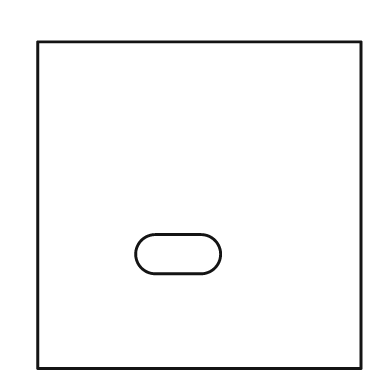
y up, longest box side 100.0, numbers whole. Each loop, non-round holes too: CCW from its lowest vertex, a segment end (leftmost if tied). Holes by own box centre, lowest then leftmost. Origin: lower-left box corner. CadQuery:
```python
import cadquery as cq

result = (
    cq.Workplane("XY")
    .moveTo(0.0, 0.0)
    .lineTo(99.0, 0.0)
    .lineTo(99.0, 100.0)
    .lineTo(0.0, 100.0)
    .close()
    .moveTo(36.0, 29.0)
    .lineTo(50.0, 29.0)
    .threePointArc((56.0, 35.0), (50.0, 41.0))
    .lineTo(36.0, 41.0)
    .threePointArc((30.0, 35.0), (36.0, 29.0))
    .close()
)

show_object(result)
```